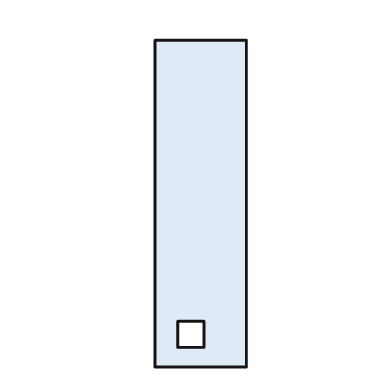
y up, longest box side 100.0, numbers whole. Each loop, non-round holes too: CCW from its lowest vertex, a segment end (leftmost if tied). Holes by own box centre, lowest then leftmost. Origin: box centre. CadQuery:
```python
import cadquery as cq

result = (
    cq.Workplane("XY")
    .moveTo(-14.0, -50.0)
    .lineTo(14.0, -50.0)
    .lineTo(14.0, 50.0)
    .lineTo(-14.0, 50.0)
    .close()
    .moveTo(-7.0, -44.0)
    .lineTo(1.0, -44.0)
    .lineTo(1.0, -36.0)
    .lineTo(-7.0, -36.0)
    .close()
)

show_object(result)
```